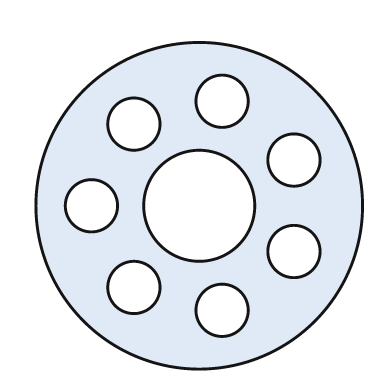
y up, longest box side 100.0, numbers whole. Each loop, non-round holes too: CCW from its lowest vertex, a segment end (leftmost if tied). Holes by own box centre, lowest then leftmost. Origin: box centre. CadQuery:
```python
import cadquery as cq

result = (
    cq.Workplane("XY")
    .moveTo(0.0, 0.0)
    .circle(50.0)
    .moveTo(7.0, -32.0)
    .circle(8.0)
    .moveTo(-20.0, -25.0)
    .circle(8.0)
    .moveTo(29.0, -14.0)
    .circle(8.0)
    .moveTo(-33.0, 0.0)
    .circle(8.0)
    .moveTo(0.0, 0.0)
    .circle(17.0)
    .moveTo(29.0, 14.0)
    .circle(8.0)
    .moveTo(-20.0, 25.0)
    .circle(8.0)
    .moveTo(7.0, 32.0)
    .circle(8.0)
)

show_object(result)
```